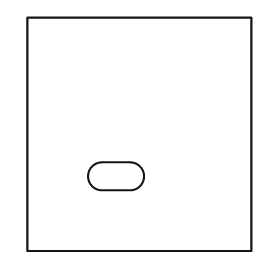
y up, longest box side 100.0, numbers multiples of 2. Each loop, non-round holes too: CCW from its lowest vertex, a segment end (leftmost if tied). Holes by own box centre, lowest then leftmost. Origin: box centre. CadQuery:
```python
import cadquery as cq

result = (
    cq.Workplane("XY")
    .moveTo(-48.0, -50.0)
    .lineTo(48.0, -50.0)
    .lineTo(48.0, 50.0)
    .lineTo(-48.0, 50.0)
    .close()
    .moveTo(-16.0, -24.0)
    .lineTo(-4.0, -24.0)
    .threePointArc((2.0, -18.0), (-4.0, -12.0))
    .lineTo(-16.0, -12.0)
    .threePointArc((-22.0, -18.0), (-16.0, -24.0))
    .close()
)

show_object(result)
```